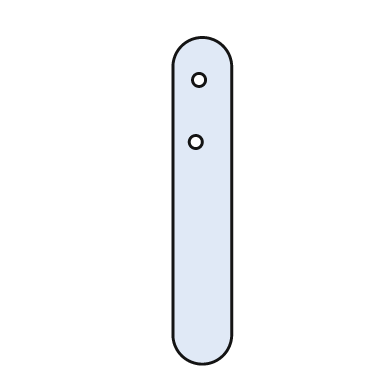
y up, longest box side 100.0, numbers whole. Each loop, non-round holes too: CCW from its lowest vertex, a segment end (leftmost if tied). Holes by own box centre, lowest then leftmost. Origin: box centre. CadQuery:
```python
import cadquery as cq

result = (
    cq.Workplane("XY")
    .moveTo(-9.0, -41.0)
    .threePointArc((0.0, -50.0), (9.0, -41.0))
    .lineTo(9.0, 41.0)
    .threePointArc((0.0, 50.0), (-9.0, 41.0))
    .close()
    .moveTo(-2.0, 18.0)
    .circle(2.0)
    .moveTo(-1.0, 37.0)
    .circle(2.0)
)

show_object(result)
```